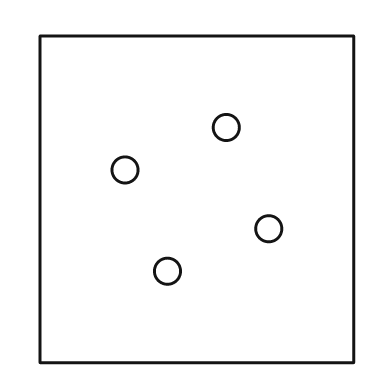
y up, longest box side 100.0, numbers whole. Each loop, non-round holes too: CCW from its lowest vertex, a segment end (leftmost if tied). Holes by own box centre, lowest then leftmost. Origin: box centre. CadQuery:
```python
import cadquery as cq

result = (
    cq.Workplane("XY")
    .moveTo(-48.0, -50.0)
    .lineTo(48.0, -50.0)
    .lineTo(48.0, 50.0)
    .lineTo(-48.0, 50.0)
    .close()
    .moveTo(-9.0, -22.0)
    .circle(4.0)
    .moveTo(22.0, -9.0)
    .circle(4.0)
    .moveTo(-22.0, 9.0)
    .circle(4.0)
    .moveTo(9.0, 22.0)
    .circle(4.0)
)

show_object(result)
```